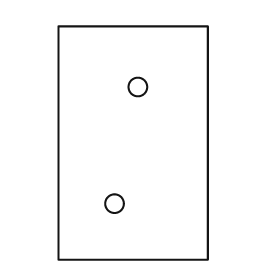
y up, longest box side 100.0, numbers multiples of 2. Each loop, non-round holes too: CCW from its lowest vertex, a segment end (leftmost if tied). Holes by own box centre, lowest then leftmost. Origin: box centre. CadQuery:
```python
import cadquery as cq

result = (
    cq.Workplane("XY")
    .moveTo(-32.0, -50.0)
    .lineTo(32.0, -50.0)
    .lineTo(32.0, 50.0)
    .lineTo(-32.0, 50.0)
    .close()
    .moveTo(-8.0, -26.0)
    .circle(4.0)
    .moveTo(2.0, 24.0)
    .circle(4.0)
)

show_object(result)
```